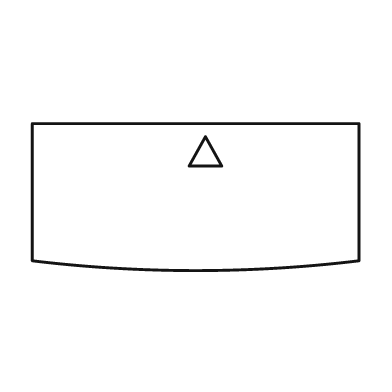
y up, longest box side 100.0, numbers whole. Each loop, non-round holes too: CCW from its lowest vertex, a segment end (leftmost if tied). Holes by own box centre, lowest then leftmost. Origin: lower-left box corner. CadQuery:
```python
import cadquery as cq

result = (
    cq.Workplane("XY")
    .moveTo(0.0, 3.0)
    .threePointArc((50.0, 0.0), (100.0, 3.0))
    .lineTo(100.0, 45.0)
    .lineTo(0.0, 45.0)
    .close()
    .moveTo(48.0, 32.0)
    .lineTo(58.0, 32.0)
    .lineTo(53.0, 41.0)
    .close()
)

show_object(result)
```